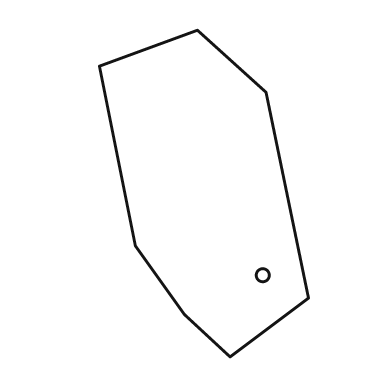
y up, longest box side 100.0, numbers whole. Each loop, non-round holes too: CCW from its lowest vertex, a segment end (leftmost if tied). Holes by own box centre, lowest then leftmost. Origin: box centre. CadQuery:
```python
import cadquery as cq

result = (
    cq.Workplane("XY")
    .moveTo(8.0, -50.0)
    .lineTo(32.0, -32.0)
    .lineTo(19.0, 31.0)
    .lineTo(-2.0, 50.0)
    .lineTo(-32.0, 39.0)
    .lineTo(-21.0, -16.0)
    .lineTo(-6.0, -37.0)
    .close()
    .moveTo(18.0, -25.0)
    .circle(2.0)
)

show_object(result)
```